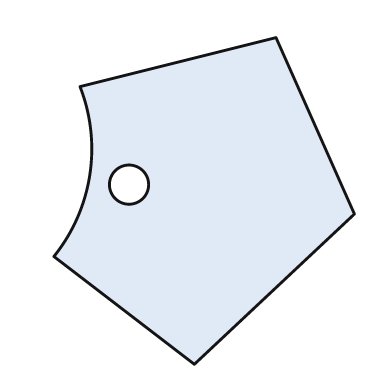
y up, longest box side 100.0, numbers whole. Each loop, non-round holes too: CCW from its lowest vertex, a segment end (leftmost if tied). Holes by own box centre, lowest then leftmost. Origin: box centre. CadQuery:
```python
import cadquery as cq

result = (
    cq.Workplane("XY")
    .moveTo(-3.0, -50.0)
    .lineTo(46.0, -4.0)
    .lineTo(22.0, 50.0)
    .lineTo(-38.0, 35.0)
    .threePointArc((-35.0, 8.0), (-46.0, -17.0))
    .close()
    .moveTo(-23.0, 5.0)
    .circle(6.0)
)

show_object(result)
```